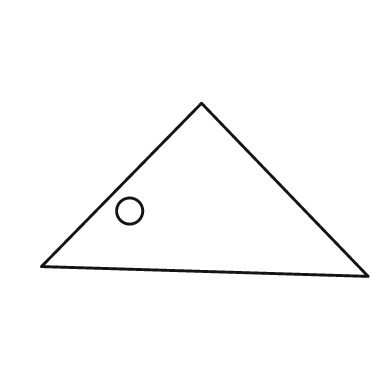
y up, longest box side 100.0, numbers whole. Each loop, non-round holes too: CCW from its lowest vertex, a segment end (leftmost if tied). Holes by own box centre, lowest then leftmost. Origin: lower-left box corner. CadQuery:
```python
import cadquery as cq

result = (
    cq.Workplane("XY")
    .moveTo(100.0, 0.0)
    .lineTo(49.0, 53.0)
    .lineTo(0.0, 3.0)
    .close()
    .moveTo(27.0, 20.0)
    .circle(4.0)
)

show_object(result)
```